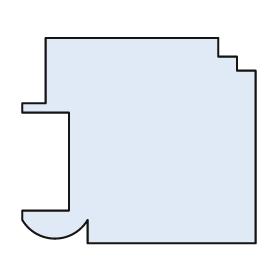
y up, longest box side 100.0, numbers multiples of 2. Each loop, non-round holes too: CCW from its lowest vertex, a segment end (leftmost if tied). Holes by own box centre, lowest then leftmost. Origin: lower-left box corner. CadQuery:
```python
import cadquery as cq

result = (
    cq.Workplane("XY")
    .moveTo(28.0, 0.0)
    .lineTo(100.0, 0.0)
    .lineTo(100.0, 74.0)
    .lineTo(92.0, 74.0)
    .lineTo(92.0, 80.0)
    .lineTo(84.0, 80.0)
    .lineTo(84.0, 88.0)
    .lineTo(10.0, 88.0)
    .lineTo(10.0, 60.0)
    .lineTo(0.0, 60.0)
    .lineTo(0.0, 56.0)
    .lineTo(20.0, 56.0)
    .lineTo(20.0, 14.0)
    .lineTo(0.0, 14.0)
    .lineTo(0.0, 10.0)
    .threePointArc((14.0, 2.0), (28.0, 10.0))
    .close()
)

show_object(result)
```